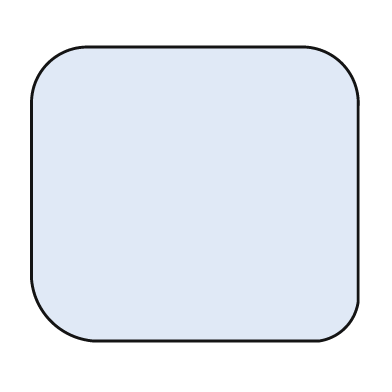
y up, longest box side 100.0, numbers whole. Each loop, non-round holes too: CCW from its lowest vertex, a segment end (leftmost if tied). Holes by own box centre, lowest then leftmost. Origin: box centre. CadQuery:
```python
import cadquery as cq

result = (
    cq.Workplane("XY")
    .moveTo(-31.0, -45.0)
    .lineTo(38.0, -45.0)
    .threePointArc((46.0, -41.0), (50.0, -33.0))
    .lineTo(50.0, 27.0)
    .threePointArc((45.0, 40.0), (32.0, 45.0))
    .lineTo(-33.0, 45.0)
    .threePointArc((-45.0, 40.0), (-50.0, 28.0))
    .lineTo(-50.0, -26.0)
    .threePointArc((-44.0, -39.0), (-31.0, -45.0))
    .close()
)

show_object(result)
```